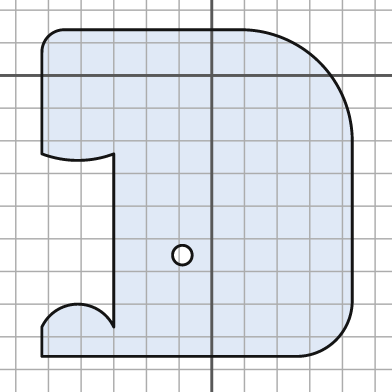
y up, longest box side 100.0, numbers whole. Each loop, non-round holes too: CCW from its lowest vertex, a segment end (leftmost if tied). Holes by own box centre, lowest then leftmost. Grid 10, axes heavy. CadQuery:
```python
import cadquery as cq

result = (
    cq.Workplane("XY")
    .moveTo(-52.0, -86.0)
    .lineTo(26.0, -86.0)
    .threePointArc((38.0, -81.0), (43.0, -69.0))
    .lineTo(43.0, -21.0)
    .threePointArc((33.0, 4.0), (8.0, 14.0))
    .lineTo(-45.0, 14.0)
    .threePointArc((-50.0, 12.0), (-52.0, 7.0))
    .lineTo(-52.0, -24.0)
    .threePointArc((-41.0, -26.0), (-30.0, -24.0))
    .lineTo(-30.0, -77.0)
    .threePointArc((-41.0, -70.0), (-52.0, -77.0))
    .close()
    .moveTo(-9.0, -55.0)
    .circle(3.0)
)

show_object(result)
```